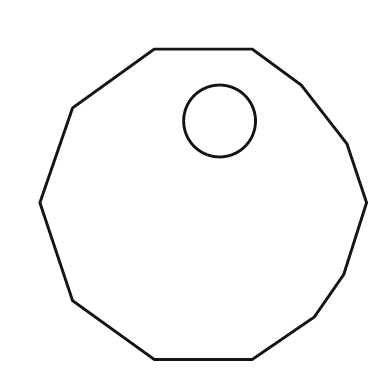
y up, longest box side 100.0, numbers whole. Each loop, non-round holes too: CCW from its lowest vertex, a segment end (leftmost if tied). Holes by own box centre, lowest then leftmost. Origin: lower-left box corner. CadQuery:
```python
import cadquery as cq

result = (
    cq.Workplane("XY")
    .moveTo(35.0, 0.0)
    .lineTo(65.0, 0.0)
    .lineTo(84.0, 13.0)
    .lineTo(93.0, 26.0)
    .lineTo(100.0, 48.0)
    .lineTo(94.0, 66.0)
    .lineTo(80.0, 84.0)
    .lineTo(65.0, 95.0)
    .lineTo(35.0, 95.0)
    .lineTo(10.0, 77.0)
    .lineTo(0.0, 48.0)
    .lineTo(10.0, 18.0)
    .close()
    .moveTo(55.0, 73.0)
    .circle(11.0)
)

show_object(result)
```